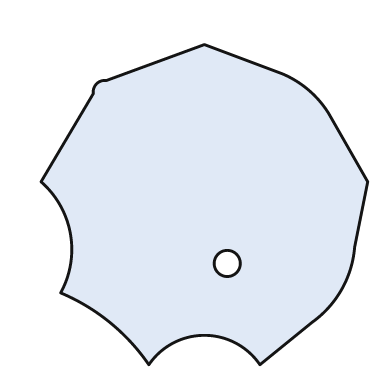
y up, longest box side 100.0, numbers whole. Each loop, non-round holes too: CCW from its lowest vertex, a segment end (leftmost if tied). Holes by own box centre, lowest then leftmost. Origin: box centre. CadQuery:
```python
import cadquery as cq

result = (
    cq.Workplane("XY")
    .moveTo(-17.0, -49.0)
    .threePointArc((0.0, -40.0), (17.0, -49.0))
    .lineTo(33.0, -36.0)
    .threePointArc((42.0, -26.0), (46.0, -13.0))
    .lineTo(50.0, 7.0)
    .lineTo(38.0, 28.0)
    .threePointArc((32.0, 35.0), (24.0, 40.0))
    .lineTo(0.0, 49.0)
    .lineTo(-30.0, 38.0)
    .threePointArc((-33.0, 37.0), (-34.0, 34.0))
    .lineTo(-50.0, 7.0)
    .threePointArc((-41.0, -9.0), (-44.0, -27.0))
    .threePointArc((-29.0, -36.0), (-17.0, -49.0))
    .close()
    .moveTo(7.0, -18.0)
    .circle(4.0)
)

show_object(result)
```